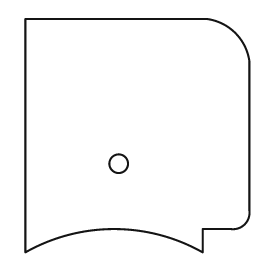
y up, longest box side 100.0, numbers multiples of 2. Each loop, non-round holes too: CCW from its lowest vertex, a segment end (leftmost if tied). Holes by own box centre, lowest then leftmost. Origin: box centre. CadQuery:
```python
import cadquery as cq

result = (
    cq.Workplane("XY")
    .moveTo(-48.0, -50.0)
    .threePointArc((-10.0, -40.0), (28.0, -50.0))
    .lineTo(28.0, -40.0)
    .lineTo(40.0, -40.0)
    .threePointArc((46.0, -38.0), (48.0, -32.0))
    .lineTo(48.0, 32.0)
    .threePointArc((42.0, 44.0), (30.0, 50.0))
    .lineTo(-48.0, 50.0)
    .close()
    .moveTo(-8.0, -12.0)
    .circle(4.0)
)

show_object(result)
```